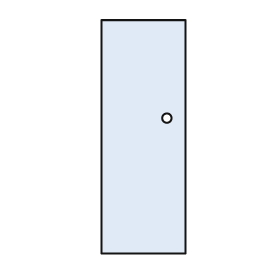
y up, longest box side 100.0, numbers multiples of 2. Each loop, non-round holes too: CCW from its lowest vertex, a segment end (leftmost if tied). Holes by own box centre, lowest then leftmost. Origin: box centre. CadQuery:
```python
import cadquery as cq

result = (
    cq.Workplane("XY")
    .moveTo(-18.0, -50.0)
    .lineTo(18.0, -50.0)
    .lineTo(18.0, 50.0)
    .lineTo(-18.0, 50.0)
    .close()
    .moveTo(10.0, 8.0)
    .circle(2.0)
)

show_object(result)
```